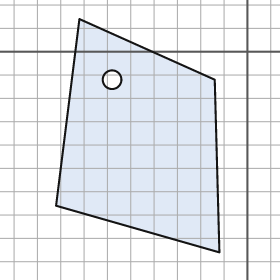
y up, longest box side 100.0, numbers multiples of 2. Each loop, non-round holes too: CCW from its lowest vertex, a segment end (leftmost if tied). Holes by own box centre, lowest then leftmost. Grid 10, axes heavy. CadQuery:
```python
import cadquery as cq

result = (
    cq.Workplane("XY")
    .moveTo(-12.0, -86.0)
    .lineTo(-14.0, -12.0)
    .lineTo(-72.0, 14.0)
    .lineTo(-82.0, -66.0)
    .close()
    .moveTo(-58.0, -12.0)
    .circle(4.0)
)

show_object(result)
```